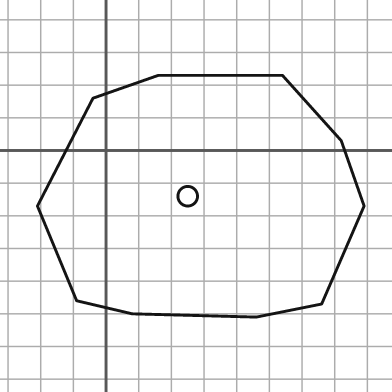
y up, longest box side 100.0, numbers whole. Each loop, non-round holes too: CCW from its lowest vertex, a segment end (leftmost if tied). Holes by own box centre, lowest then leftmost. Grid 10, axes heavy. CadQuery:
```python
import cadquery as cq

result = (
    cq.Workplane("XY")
    .moveTo(46.0, -51.0)
    .lineTo(66.0, -47.0)
    .lineTo(79.0, -17.0)
    .lineTo(72.0, 3.0)
    .lineTo(54.0, 23.0)
    .lineTo(16.0, 23.0)
    .lineTo(-4.0, 16.0)
    .lineTo(-21.0, -17.0)
    .lineTo(-9.0, -46.0)
    .lineTo(8.0, -50.0)
    .close()
    .moveTo(25.0, -14.0)
    .circle(3.0)
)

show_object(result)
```